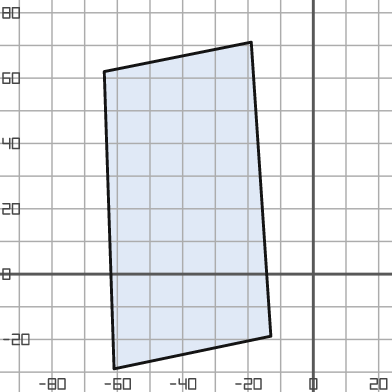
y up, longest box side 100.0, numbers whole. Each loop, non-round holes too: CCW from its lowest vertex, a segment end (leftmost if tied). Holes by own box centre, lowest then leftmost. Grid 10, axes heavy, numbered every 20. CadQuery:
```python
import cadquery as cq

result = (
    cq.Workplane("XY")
    .moveTo(-61.0, -29.0)
    .lineTo(-13.0, -19.0)
    .lineTo(-19.0, 71.0)
    .lineTo(-64.0, 62.0)
    .close()
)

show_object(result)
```